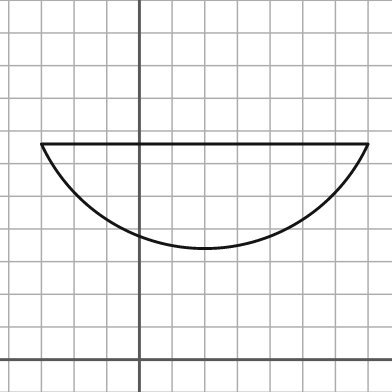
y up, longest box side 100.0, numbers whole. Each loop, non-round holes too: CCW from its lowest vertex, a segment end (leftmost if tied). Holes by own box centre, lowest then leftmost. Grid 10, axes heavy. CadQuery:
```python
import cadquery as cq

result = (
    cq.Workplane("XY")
    .moveTo(-30.0, 66.0)
    .threePointArc((20.0, 34.0), (70.0, 66.0))
    .close()
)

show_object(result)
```